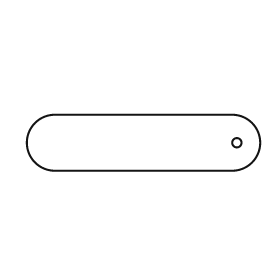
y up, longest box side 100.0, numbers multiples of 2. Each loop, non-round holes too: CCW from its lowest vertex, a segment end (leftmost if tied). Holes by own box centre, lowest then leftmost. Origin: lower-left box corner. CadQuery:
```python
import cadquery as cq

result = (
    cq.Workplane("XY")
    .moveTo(12.0, 0.0)
    .lineTo(88.0, 0.0)
    .threePointArc((100.0, 12.0), (88.0, 24.0))
    .lineTo(12.0, 24.0)
    .threePointArc((0.0, 12.0), (12.0, 0.0))
    .close()
    .moveTo(90.0, 12.0)
    .circle(2.0)
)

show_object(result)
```